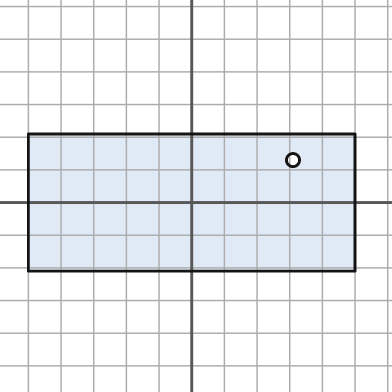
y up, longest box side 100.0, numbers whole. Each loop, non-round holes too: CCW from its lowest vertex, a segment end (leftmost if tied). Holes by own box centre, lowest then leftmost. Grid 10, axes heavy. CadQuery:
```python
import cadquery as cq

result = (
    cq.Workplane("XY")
    .moveTo(-50.0, -21.0)
    .lineTo(50.0, -21.0)
    .lineTo(50.0, 21.0)
    .lineTo(-50.0, 21.0)
    .close()
    .moveTo(31.0, 13.0)
    .circle(2.0)
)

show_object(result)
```